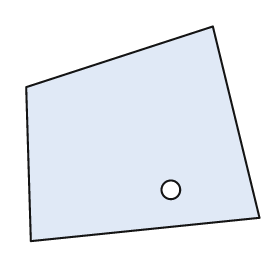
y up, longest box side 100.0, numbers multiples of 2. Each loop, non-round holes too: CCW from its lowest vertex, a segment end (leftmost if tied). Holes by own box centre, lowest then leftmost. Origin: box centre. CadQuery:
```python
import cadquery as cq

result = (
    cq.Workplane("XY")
    .moveTo(-48.0, -46.0)
    .lineTo(50.0, -36.0)
    .lineTo(30.0, 46.0)
    .lineTo(-50.0, 20.0)
    .close()
    .moveTo(12.0, -24.0)
    .circle(4.0)
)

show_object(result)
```